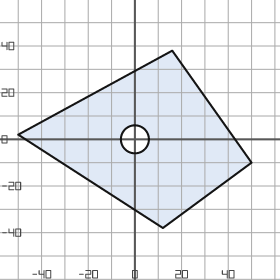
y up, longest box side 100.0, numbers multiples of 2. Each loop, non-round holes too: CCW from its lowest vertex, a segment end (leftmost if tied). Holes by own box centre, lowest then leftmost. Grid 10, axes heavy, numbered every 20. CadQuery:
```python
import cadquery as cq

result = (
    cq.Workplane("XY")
    .moveTo(12.0, -38.0)
    .lineTo(50.0, -10.0)
    .lineTo(16.0, 38.0)
    .lineTo(-50.0, 2.0)
    .close()
    .moveTo(0.0, 0.0)
    .circle(6.0)
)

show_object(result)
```